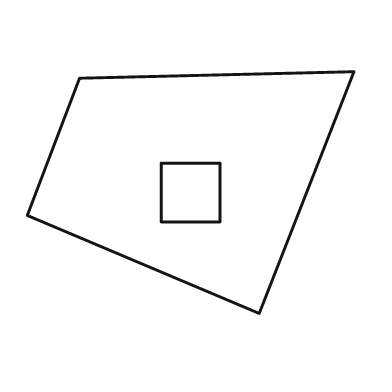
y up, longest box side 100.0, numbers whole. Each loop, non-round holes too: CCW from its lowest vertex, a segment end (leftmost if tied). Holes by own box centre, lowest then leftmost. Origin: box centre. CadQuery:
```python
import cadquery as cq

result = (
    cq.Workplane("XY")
    .moveTo(21.0, -37.0)
    .lineTo(50.0, 37.0)
    .lineTo(-34.0, 35.0)
    .lineTo(-50.0, -7.0)
    .close()
    .moveTo(-9.0, -9.0)
    .lineTo(9.0, -9.0)
    .lineTo(9.0, 9.0)
    .lineTo(-9.0, 9.0)
    .close()
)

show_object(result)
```